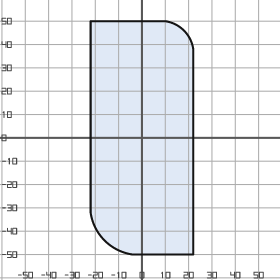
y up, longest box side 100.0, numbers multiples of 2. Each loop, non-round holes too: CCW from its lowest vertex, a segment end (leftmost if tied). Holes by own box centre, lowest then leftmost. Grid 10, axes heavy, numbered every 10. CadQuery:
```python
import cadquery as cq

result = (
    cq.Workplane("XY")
    .moveTo(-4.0, -50.0)
    .lineTo(22.0, -50.0)
    .lineTo(22.0, 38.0)
    .threePointArc((18.0, 46.0), (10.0, 50.0))
    .lineTo(-22.0, 50.0)
    .lineTo(-22.0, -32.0)
    .threePointArc((-16.0, -44.0), (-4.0, -50.0))
    .close()
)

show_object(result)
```